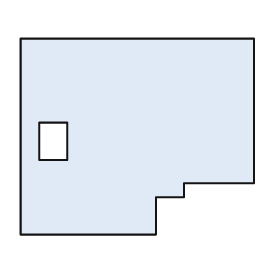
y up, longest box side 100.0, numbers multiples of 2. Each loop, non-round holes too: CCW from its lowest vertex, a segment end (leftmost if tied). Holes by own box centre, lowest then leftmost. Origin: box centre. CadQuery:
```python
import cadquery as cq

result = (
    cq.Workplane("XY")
    .moveTo(-50.0, -42.0)
    .lineTo(8.0, -42.0)
    .lineTo(8.0, -26.0)
    .lineTo(20.0, -26.0)
    .lineTo(20.0, -20.0)
    .lineTo(50.0, -20.0)
    .lineTo(50.0, 42.0)
    .lineTo(-50.0, 42.0)
    .close()
    .moveTo(-42.0, -10.0)
    .lineTo(-30.0, -10.0)
    .lineTo(-30.0, 6.0)
    .lineTo(-42.0, 6.0)
    .close()
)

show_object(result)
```